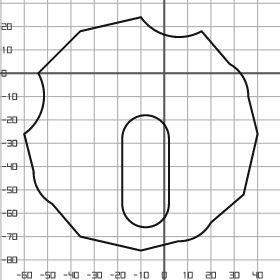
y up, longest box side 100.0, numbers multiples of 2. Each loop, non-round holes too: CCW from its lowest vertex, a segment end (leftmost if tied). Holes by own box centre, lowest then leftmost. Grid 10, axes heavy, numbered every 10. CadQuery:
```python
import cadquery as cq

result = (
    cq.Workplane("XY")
    .moveTo(-10.0, -76.0)
    .lineTo(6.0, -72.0)
    .threePointArc((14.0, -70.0), (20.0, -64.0))
    .lineTo(34.0, -52.0)
    .lineTo(40.0, -26.0)
    .lineTo(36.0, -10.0)
    .threePointArc((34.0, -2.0), (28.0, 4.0))
    .lineTo(16.0, 18.0)
    .threePointArc((2.0, 16.0), (-10.0, 24.0))
    .lineTo(-36.0, 18.0)
    .lineTo(-54.0, 0.0)
    .threePointArc((-52.0, -14.0), (-60.0, -26.0))
    .lineTo(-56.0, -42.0)
    .threePointArc((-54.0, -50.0), (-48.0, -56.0))
    .lineTo(-36.0, -70.0)
    .close()
    .moveTo(-18.0, -56.0)
    .threePointArc((-8.0, -66.0), (2.0, -56.0))
    .lineTo(2.0, -28.0)
    .threePointArc((-8.0, -18.0), (-18.0, -28.0))
    .close()
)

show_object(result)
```